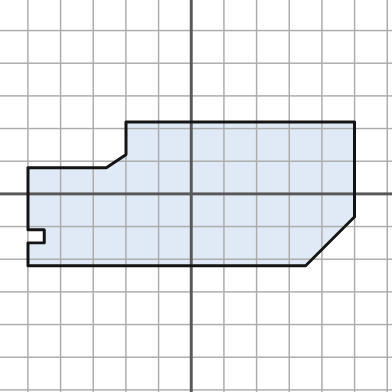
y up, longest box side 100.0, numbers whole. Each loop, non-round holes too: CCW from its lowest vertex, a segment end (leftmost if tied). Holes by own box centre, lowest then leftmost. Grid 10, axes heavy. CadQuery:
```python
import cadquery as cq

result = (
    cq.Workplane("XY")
    .moveTo(-50.0, -22.0)
    .lineTo(35.0, -22.0)
    .lineTo(50.0, -7.0)
    .lineTo(50.0, 22.0)
    .lineTo(-20.0, 22.0)
    .lineTo(-20.0, 12.0)
    .lineTo(-26.0, 8.0)
    .lineTo(-50.0, 8.0)
    .lineTo(-50.0, -11.0)
    .lineTo(-45.0, -11.0)
    .lineTo(-45.0, -15.0)
    .lineTo(-50.0, -15.0)
    .close()
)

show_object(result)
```